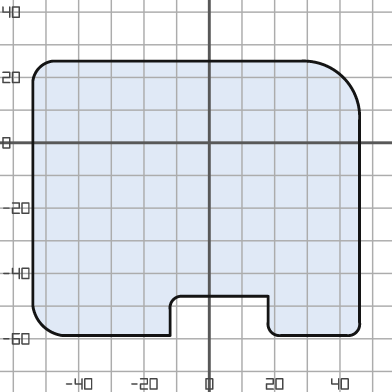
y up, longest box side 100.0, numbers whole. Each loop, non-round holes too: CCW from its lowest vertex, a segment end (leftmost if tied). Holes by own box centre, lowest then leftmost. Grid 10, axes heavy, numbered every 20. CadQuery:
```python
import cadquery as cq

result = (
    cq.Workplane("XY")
    .moveTo(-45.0, -59.0)
    .lineTo(-12.0, -59.0)
    .lineTo(-12.0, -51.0)
    .threePointArc((-11.0, -48.0), (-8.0, -47.0))
    .lineTo(18.0, -47.0)
    .lineTo(18.0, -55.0)
    .threePointArc((19.0, -58.0), (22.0, -59.0))
    .lineTo(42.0, -59.0)
    .threePointArc((45.0, -58.0), (46.0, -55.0))
    .lineTo(46.0, 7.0)
    .threePointArc((41.0, 20.0), (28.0, 25.0))
    .lineTo(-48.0, 25.0)
    .threePointArc((-52.0, 23.0), (-54.0, 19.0))
    .lineTo(-54.0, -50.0)
    .threePointArc((-51.0, -56.0), (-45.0, -59.0))
    .close()
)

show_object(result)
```